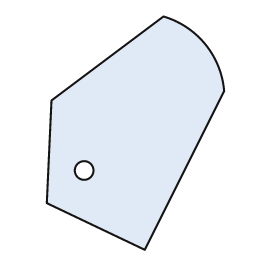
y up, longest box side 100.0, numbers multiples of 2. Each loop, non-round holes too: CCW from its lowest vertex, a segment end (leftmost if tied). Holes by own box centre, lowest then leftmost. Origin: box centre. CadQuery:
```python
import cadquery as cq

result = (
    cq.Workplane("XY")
    .moveTo(4.0, -50.0)
    .lineTo(38.0, 18.0)
    .threePointArc((30.0, 38.0), (12.0, 50.0))
    .lineTo(-36.0, 14.0)
    .lineTo(-38.0, -30.0)
    .close()
    .moveTo(-22.0, -16.0)
    .circle(4.0)
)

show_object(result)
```